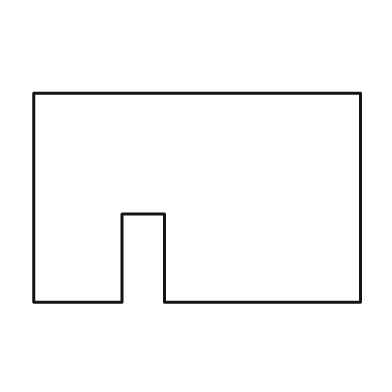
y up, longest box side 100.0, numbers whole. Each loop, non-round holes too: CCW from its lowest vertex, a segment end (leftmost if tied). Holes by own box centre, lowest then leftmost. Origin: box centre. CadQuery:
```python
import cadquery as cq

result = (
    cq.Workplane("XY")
    .moveTo(-50.0, -32.0)
    .lineTo(-23.0, -32.0)
    .lineTo(-23.0, -5.0)
    .lineTo(-10.0, -5.0)
    .lineTo(-10.0, -32.0)
    .lineTo(50.0, -32.0)
    .lineTo(50.0, 32.0)
    .lineTo(-50.0, 32.0)
    .close()
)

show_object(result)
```